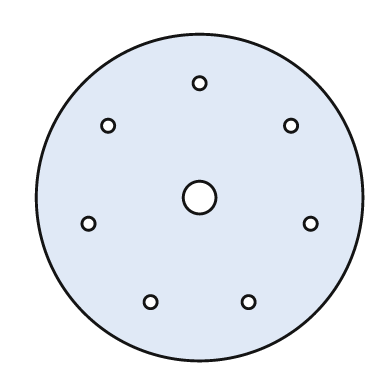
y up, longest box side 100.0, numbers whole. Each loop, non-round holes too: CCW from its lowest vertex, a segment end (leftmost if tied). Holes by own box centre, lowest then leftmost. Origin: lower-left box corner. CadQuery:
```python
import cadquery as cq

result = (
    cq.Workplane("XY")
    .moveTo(50.0, 50.0)
    .circle(50.0)
    .moveTo(35.0, 18.0)
    .circle(2.0)
    .moveTo(65.0, 18.0)
    .circle(2.0)
    .moveTo(16.0, 42.0)
    .circle(2.0)
    .moveTo(84.0, 42.0)
    .circle(2.0)
    .moveTo(50.0, 50.0)
    .circle(5.0)
    .moveTo(22.0, 72.0)
    .circle(2.0)
    .moveTo(78.0, 72.0)
    .circle(2.0)
    .moveTo(50.0, 85.0)
    .circle(2.0)
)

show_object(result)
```